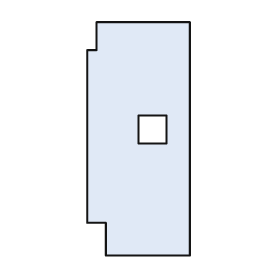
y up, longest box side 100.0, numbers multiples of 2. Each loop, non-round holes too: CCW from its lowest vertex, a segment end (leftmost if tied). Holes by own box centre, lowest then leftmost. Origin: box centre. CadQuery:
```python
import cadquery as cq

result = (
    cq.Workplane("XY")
    .moveTo(-14.0, -50.0)
    .lineTo(22.0, -50.0)
    .lineTo(22.0, 50.0)
    .lineTo(-18.0, 50.0)
    .lineTo(-18.0, 38.0)
    .lineTo(-22.0, 38.0)
    .lineTo(-22.0, -36.0)
    .lineTo(-14.0, -36.0)
    .close()
    .moveTo(0.0, -2.0)
    .lineTo(12.0, -2.0)
    .lineTo(12.0, 10.0)
    .lineTo(0.0, 10.0)
    .close()
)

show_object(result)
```